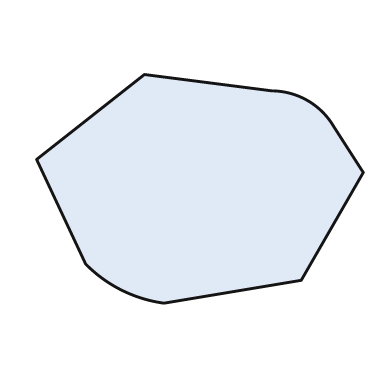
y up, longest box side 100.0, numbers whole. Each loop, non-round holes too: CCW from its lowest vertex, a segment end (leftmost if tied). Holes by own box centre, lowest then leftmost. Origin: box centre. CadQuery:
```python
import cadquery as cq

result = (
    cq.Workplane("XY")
    .moveTo(-11.0, -35.0)
    .lineTo(31.0, -28.0)
    .lineTo(50.0, 5.0)
    .lineTo(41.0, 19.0)
    .threePointArc((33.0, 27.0), (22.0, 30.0))
    .lineTo(-17.0, 35.0)
    .lineTo(-50.0, 9.0)
    .lineTo(-35.0, -23.0)
    .threePointArc((-24.0, -31.0), (-11.0, -35.0))
    .close()
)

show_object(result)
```